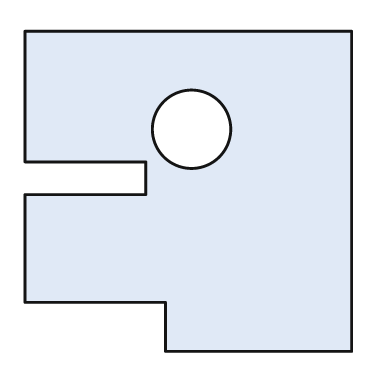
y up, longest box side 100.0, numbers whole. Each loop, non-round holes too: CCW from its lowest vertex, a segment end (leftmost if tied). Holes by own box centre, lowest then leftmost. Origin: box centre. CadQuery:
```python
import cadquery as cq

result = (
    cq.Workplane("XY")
    .moveTo(-7.0, -49.0)
    .lineTo(50.0, -49.0)
    .lineTo(50.0, 49.0)
    .lineTo(-50.0, 49.0)
    .lineTo(-50.0, 9.0)
    .lineTo(-13.0, 9.0)
    .lineTo(-13.0, -1.0)
    .lineTo(-50.0, -1.0)
    .lineTo(-50.0, -34.0)
    .lineTo(-7.0, -34.0)
    .close()
    .moveTo(1.0, 19.0)
    .circle(12.0)
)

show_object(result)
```